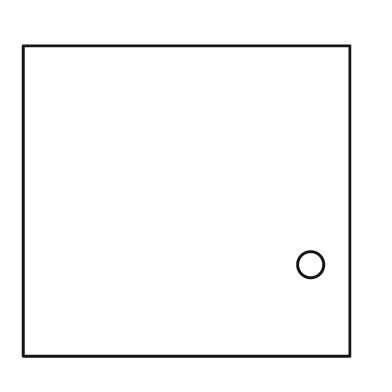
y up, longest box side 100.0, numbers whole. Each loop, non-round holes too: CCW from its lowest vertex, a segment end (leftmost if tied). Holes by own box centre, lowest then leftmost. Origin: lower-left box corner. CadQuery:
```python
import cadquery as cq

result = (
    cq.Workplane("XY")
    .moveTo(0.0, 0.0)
    .lineTo(100.0, 0.0)
    .lineTo(100.0, 95.0)
    .lineTo(0.0, 95.0)
    .close()
    .moveTo(88.0, 28.0)
    .circle(4.0)
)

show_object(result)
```